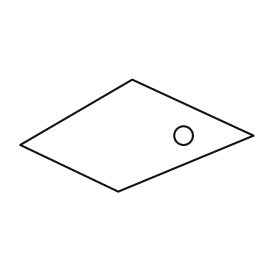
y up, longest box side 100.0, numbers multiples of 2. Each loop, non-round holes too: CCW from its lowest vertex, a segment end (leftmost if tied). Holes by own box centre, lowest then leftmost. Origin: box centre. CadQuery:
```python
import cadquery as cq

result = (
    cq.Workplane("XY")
    .moveTo(-8.0, -24.0)
    .lineTo(50.0, 0.0)
    .lineTo(-2.0, 24.0)
    .lineTo(-50.0, -4.0)
    .close()
    .moveTo(20.0, 0.0)
    .circle(4.0)
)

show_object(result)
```